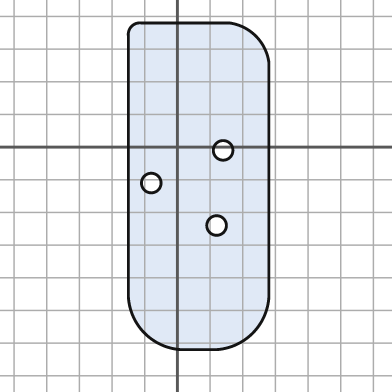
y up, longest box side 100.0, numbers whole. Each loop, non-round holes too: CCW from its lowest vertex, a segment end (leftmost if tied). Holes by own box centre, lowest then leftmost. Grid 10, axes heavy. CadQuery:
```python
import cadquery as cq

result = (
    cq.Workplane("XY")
    .moveTo(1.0, -62.0)
    .lineTo(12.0, -62.0)
    .threePointArc((23.0, -57.0), (28.0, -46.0))
    .lineTo(28.0, 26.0)
    .threePointArc((24.0, 34.0), (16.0, 38.0))
    .lineTo(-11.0, 38.0)
    .threePointArc((-14.0, 37.0), (-15.0, 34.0))
    .lineTo(-15.0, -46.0)
    .threePointArc((-10.0, -57.0), (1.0, -62.0))
    .close()
    .moveTo(12.0, -24.0)
    .circle(3.0)
    .moveTo(-8.0, -11.0)
    .circle(3.0)
    .moveTo(14.0, -1.0)
    .circle(3.0)
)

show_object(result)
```